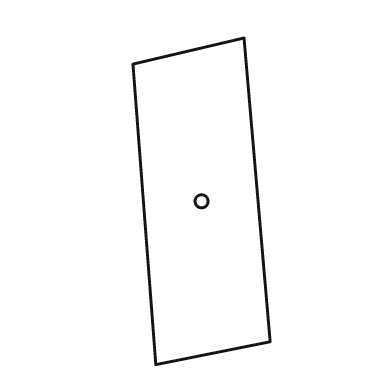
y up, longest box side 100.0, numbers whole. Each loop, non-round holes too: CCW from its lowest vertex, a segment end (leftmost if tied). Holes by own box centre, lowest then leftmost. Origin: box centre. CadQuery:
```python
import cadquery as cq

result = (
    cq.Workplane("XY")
    .moveTo(-14.0, -50.0)
    .lineTo(21.0, -43.0)
    .lineTo(13.0, 50.0)
    .lineTo(-21.0, 42.0)
    .close()
    .moveTo(0.0, 0.0)
    .circle(2.0)
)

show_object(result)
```